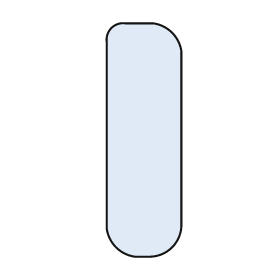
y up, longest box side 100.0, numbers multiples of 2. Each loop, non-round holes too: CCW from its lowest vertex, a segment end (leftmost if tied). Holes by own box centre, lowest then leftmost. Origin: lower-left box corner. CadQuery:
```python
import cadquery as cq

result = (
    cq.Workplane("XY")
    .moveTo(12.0, 0.0)
    .lineTo(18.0, 0.0)
    .threePointArc((28.0, 4.0), (32.0, 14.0))
    .lineTo(32.0, 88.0)
    .threePointArc((28.0, 96.0), (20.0, 100.0))
    .lineTo(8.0, 100.0)
    .threePointArc((2.0, 98.0), (0.0, 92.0))
    .lineTo(0.0, 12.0)
    .threePointArc((4.0, 4.0), (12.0, 0.0))
    .close()
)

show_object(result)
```